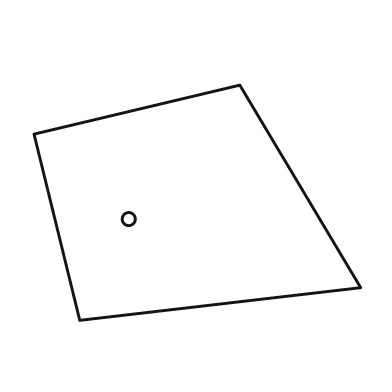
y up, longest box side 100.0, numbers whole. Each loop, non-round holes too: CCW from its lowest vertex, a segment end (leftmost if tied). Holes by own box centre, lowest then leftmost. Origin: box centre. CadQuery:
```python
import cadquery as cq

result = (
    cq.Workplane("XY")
    .moveTo(-36.0, -36.0)
    .lineTo(50.0, -26.0)
    .lineTo(13.0, 36.0)
    .lineTo(-50.0, 21.0)
    .close()
    .moveTo(-21.0, -5.0)
    .circle(2.0)
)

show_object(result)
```